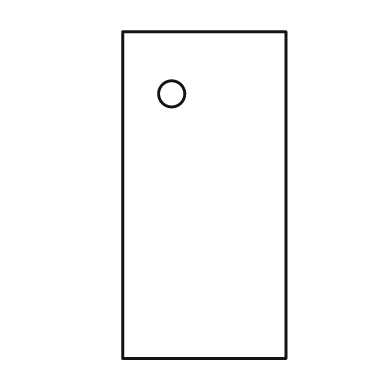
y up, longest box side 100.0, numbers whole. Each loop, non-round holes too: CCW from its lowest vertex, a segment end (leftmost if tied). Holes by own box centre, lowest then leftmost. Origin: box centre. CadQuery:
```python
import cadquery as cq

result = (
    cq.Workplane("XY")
    .moveTo(-25.0, -50.0)
    .lineTo(25.0, -50.0)
    .lineTo(25.0, 50.0)
    .lineTo(-25.0, 50.0)
    .close()
    .moveTo(-10.0, 31.0)
    .circle(4.0)
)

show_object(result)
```